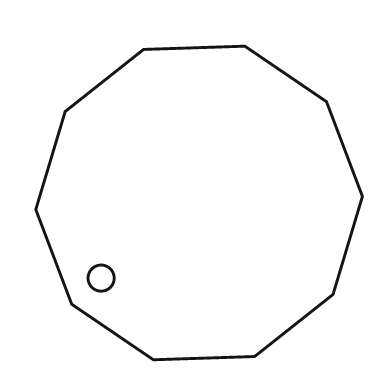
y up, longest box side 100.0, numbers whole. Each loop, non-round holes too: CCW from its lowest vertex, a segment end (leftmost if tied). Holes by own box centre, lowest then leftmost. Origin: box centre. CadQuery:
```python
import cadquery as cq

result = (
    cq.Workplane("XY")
    .moveTo(-14.0, -48.0)
    .lineTo(17.0, -47.0)
    .lineTo(41.0, -28.0)
    .lineTo(50.0, 2.0)
    .lineTo(39.0, 31.0)
    .lineTo(14.0, 48.0)
    .lineTo(-17.0, 47.0)
    .lineTo(-41.0, 28.0)
    .lineTo(-50.0, -2.0)
    .lineTo(-39.0, -31.0)
    .close()
    .moveTo(-30.0, -23.0)
    .circle(4.0)
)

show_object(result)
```